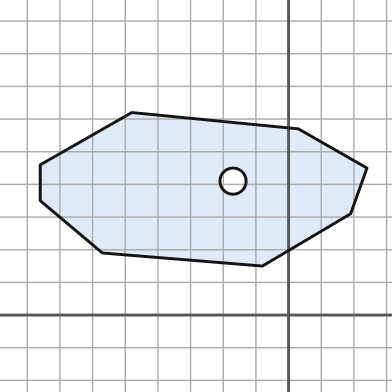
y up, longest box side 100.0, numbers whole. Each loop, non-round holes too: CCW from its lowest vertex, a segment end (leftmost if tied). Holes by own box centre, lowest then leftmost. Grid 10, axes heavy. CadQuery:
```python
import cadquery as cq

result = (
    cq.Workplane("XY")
    .moveTo(-8.0, 15.0)
    .lineTo(19.0, 31.0)
    .lineTo(24.0, 45.0)
    .lineTo(3.0, 57.0)
    .lineTo(-48.0, 62.0)
    .lineTo(-76.0, 46.0)
    .lineTo(-76.0, 35.0)
    .lineTo(-57.0, 19.0)
    .close()
    .moveTo(-17.0, 41.0)
    .circle(4.0)
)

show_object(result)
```